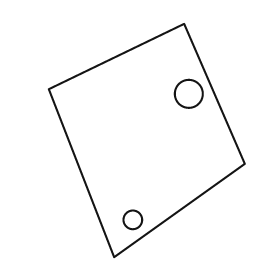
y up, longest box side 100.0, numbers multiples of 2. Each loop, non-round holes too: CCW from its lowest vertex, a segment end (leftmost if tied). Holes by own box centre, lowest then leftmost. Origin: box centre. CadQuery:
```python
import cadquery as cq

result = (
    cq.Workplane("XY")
    .moveTo(-14.0, -50.0)
    .lineTo(42.0, -10.0)
    .lineTo(16.0, 50.0)
    .lineTo(-42.0, 22.0)
    .close()
    .moveTo(-6.0, -34.0)
    .circle(4.0)
    .moveTo(18.0, 20.0)
    .circle(6.0)
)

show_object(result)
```